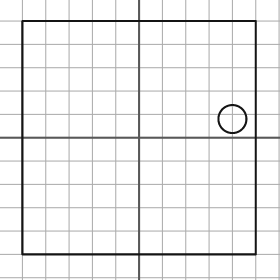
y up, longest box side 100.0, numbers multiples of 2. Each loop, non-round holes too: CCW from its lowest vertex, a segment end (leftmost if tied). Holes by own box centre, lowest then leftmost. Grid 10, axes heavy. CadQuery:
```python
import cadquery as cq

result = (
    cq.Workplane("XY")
    .moveTo(-50.0, -50.0)
    .lineTo(50.0, -50.0)
    .lineTo(50.0, 50.0)
    .lineTo(-50.0, 50.0)
    .close()
    .moveTo(40.0, 8.0)
    .circle(6.0)
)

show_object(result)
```